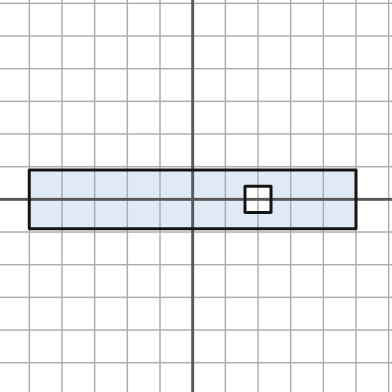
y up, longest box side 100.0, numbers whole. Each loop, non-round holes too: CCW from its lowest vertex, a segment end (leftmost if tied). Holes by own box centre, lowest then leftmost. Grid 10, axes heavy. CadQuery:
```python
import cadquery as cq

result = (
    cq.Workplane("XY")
    .moveTo(-50.0, -9.0)
    .lineTo(50.0, -9.0)
    .lineTo(50.0, 9.0)
    .lineTo(-50.0, 9.0)
    .close()
    .moveTo(16.0, -4.0)
    .lineTo(24.0, -4.0)
    .lineTo(24.0, 4.0)
    .lineTo(16.0, 4.0)
    .close()
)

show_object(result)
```